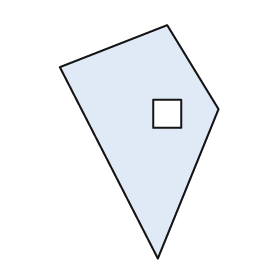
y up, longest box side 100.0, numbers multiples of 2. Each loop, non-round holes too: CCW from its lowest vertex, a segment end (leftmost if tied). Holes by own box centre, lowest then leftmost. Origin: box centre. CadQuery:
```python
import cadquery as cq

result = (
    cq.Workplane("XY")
    .moveTo(8.0, -50.0)
    .lineTo(34.0, 14.0)
    .lineTo(12.0, 50.0)
    .lineTo(-34.0, 32.0)
    .close()
    .moveTo(6.0, 6.0)
    .lineTo(18.0, 6.0)
    .lineTo(18.0, 18.0)
    .lineTo(6.0, 18.0)
    .close()
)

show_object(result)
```